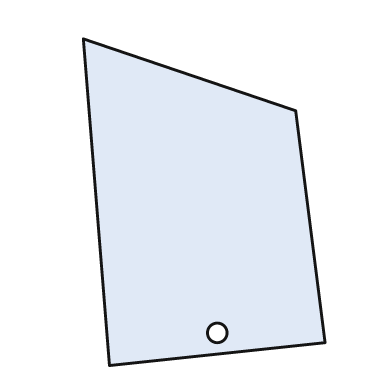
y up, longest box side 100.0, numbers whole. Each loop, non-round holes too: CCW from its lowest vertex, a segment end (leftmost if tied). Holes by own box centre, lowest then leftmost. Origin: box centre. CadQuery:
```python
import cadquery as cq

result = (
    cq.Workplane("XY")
    .moveTo(-29.0, -50.0)
    .lineTo(37.0, -43.0)
    .lineTo(28.0, 28.0)
    .lineTo(-37.0, 50.0)
    .close()
    .moveTo(4.0, -40.0)
    .circle(3.0)
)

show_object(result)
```